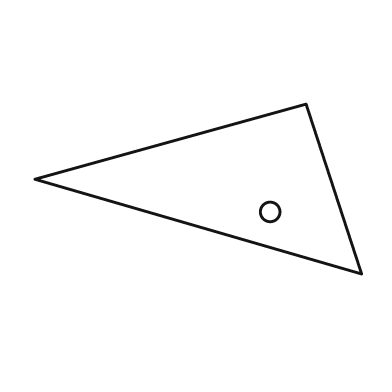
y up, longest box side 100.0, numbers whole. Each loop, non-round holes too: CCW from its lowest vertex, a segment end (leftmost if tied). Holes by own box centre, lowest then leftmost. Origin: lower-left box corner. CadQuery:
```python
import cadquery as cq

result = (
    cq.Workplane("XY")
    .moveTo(100.0, 0.0)
    .lineTo(83.0, 52.0)
    .lineTo(0.0, 29.0)
    .close()
    .moveTo(72.0, 19.0)
    .circle(3.0)
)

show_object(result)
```